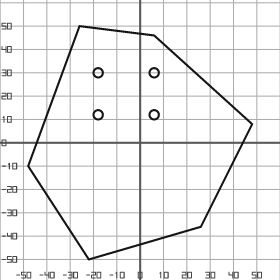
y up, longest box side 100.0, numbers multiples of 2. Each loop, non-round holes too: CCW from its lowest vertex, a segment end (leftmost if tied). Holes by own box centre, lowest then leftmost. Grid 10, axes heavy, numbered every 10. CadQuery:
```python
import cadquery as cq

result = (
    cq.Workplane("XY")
    .moveTo(-22.0, -50.0)
    .lineTo(26.0, -36.0)
    .lineTo(48.0, 8.0)
    .lineTo(6.0, 46.0)
    .lineTo(-26.0, 50.0)
    .lineTo(-48.0, -10.0)
    .close()
    .moveTo(-18.0, 12.0)
    .circle(2.0)
    .moveTo(6.0, 12.0)
    .circle(2.0)
    .moveTo(-18.0, 30.0)
    .circle(2.0)
    .moveTo(6.0, 30.0)
    .circle(2.0)
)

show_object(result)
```